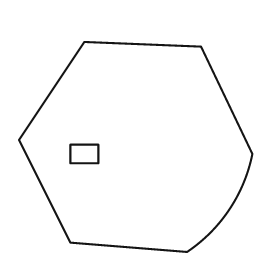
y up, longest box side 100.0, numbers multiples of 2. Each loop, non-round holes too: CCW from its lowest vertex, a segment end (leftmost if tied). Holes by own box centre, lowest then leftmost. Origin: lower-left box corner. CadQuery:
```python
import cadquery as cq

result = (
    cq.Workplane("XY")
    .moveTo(72.0, 0.0)
    .threePointArc((90.0, 18.0), (100.0, 42.0))
    .lineTo(78.0, 88.0)
    .lineTo(28.0, 90.0)
    .lineTo(0.0, 48.0)
    .lineTo(22.0, 4.0)
    .close()
    .moveTo(22.0, 38.0)
    .lineTo(34.0, 38.0)
    .lineTo(34.0, 46.0)
    .lineTo(22.0, 46.0)
    .close()
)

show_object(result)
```